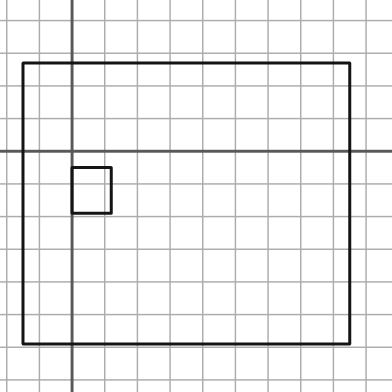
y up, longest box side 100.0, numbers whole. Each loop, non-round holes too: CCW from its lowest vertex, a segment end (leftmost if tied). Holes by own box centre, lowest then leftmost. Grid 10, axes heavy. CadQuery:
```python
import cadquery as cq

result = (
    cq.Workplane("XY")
    .moveTo(-15.0, -59.0)
    .lineTo(85.0, -59.0)
    .lineTo(85.0, 27.0)
    .lineTo(-15.0, 27.0)
    .close()
    .moveTo(0.0, -19.0)
    .lineTo(12.0, -19.0)
    .lineTo(12.0, -5.0)
    .lineTo(0.0, -5.0)
    .close()
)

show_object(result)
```